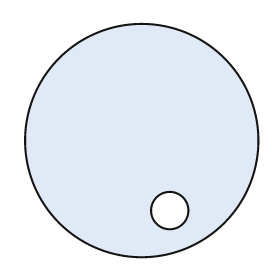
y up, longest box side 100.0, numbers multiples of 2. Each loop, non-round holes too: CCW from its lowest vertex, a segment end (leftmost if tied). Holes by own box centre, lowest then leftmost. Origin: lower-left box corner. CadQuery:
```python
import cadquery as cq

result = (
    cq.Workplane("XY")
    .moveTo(50.0, 50.0)
    .circle(50.0)
    .moveTo(62.0, 20.0)
    .circle(8.0)
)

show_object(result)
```